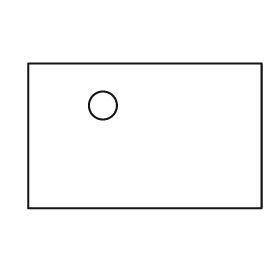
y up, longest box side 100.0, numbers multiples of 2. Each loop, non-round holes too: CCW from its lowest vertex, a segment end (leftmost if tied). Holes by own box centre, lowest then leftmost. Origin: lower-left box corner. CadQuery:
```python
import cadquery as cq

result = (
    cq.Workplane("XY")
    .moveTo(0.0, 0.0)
    .lineTo(100.0, 0.0)
    .lineTo(100.0, 62.0)
    .lineTo(0.0, 62.0)
    .close()
    .moveTo(32.0, 44.0)
    .circle(6.0)
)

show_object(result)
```